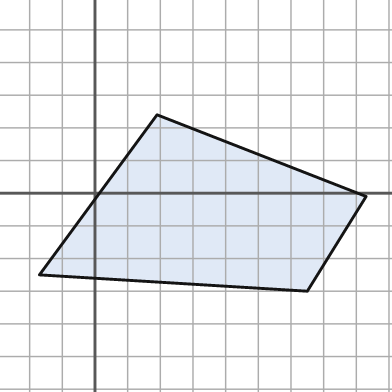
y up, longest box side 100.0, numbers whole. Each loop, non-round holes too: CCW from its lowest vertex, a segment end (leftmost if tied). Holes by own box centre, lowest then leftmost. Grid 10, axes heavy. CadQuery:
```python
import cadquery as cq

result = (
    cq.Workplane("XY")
    .moveTo(65.0, -30.0)
    .lineTo(83.0, -1.0)
    .lineTo(19.0, 24.0)
    .lineTo(-17.0, -25.0)
    .close()
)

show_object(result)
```